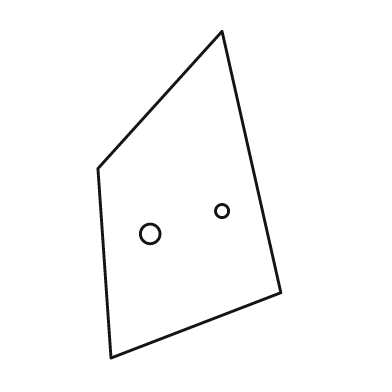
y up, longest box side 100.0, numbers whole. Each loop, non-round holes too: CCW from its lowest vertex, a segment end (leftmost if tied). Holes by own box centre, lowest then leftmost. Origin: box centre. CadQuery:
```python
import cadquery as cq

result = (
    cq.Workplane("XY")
    .moveTo(-24.0, -50.0)
    .lineTo(28.0, -30.0)
    .lineTo(10.0, 50.0)
    .lineTo(-28.0, 8.0)
    .close()
    .moveTo(-12.0, -12.0)
    .circle(3.0)
    .moveTo(10.0, -5.0)
    .circle(2.0)
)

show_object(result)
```